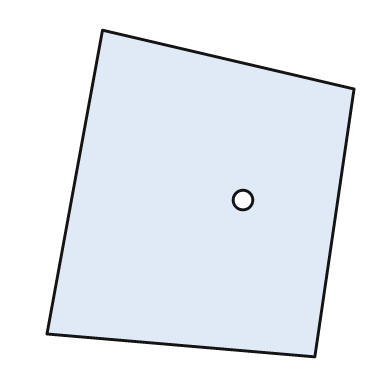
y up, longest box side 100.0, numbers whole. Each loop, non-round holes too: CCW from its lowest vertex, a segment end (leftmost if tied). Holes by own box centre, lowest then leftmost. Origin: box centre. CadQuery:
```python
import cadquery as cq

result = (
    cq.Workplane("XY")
    .moveTo(35.0, -50.0)
    .lineTo(47.0, 32.0)
    .lineTo(-30.0, 50.0)
    .lineTo(-47.0, -43.0)
    .close()
    .moveTo(13.0, -2.0)
    .circle(3.0)
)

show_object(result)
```